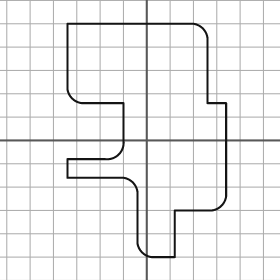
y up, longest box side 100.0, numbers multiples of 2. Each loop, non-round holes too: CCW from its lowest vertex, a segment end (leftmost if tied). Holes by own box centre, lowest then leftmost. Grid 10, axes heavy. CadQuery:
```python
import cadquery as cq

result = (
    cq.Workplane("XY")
    .moveTo(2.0, -50.0)
    .lineTo(12.0, -50.0)
    .lineTo(12.0, -30.0)
    .lineTo(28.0, -30.0)
    .threePointArc((32.0, -28.0), (34.0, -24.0))
    .lineTo(34.0, 16.0)
    .lineTo(26.0, 16.0)
    .lineTo(26.0, 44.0)
    .threePointArc((24.0, 48.0), (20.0, 50.0))
    .lineTo(-34.0, 50.0)
    .lineTo(-34.0, 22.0)
    .threePointArc((-32.0, 18.0), (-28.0, 16.0))
    .lineTo(-10.0, 16.0)
    .lineTo(-10.0, 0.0)
    .threePointArc((-12.0, -6.0), (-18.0, -8.0))
    .lineTo(-34.0, -8.0)
    .lineTo(-34.0, -16.0)
    .lineTo(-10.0, -16.0)
    .threePointArc((-6.0, -18.0), (-4.0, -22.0))
    .lineTo(-4.0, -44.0)
    .threePointArc((-2.0, -48.0), (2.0, -50.0))
    .close()
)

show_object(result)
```